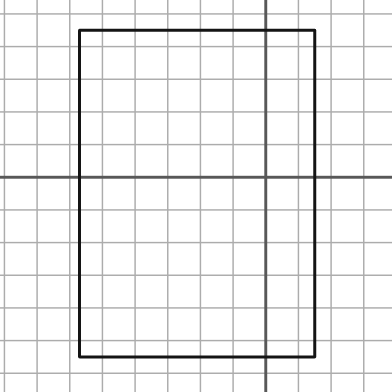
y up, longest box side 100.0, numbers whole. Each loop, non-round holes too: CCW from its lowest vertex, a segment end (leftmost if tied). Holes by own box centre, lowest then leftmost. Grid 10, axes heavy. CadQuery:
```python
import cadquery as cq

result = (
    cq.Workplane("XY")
    .moveTo(-57.0, -55.0)
    .lineTo(15.0, -55.0)
    .lineTo(15.0, 45.0)
    .lineTo(-57.0, 45.0)
    .close()
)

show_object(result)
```